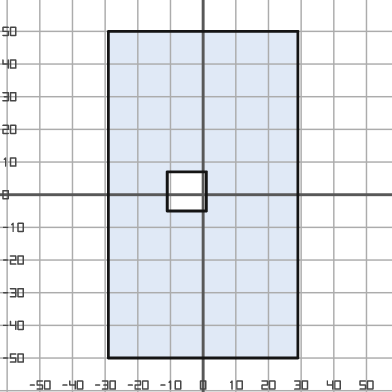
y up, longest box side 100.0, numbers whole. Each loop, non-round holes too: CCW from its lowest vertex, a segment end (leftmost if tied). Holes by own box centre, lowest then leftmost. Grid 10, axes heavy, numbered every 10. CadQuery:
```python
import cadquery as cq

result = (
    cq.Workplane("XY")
    .moveTo(-29.0, -50.0)
    .lineTo(29.0, -50.0)
    .lineTo(29.0, 50.0)
    .lineTo(-29.0, 50.0)
    .close()
    .moveTo(-11.0, -5.0)
    .lineTo(1.0, -5.0)
    .lineTo(1.0, 7.0)
    .lineTo(-11.0, 7.0)
    .close()
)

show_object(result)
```